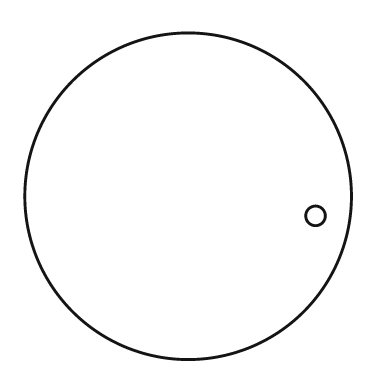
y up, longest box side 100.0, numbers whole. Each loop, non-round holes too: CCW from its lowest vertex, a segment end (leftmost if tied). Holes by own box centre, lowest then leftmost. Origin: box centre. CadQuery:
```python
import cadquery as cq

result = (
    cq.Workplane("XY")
    .moveTo(0.0, 0.0)
    .circle(50.0)
    .moveTo(39.0, -6.0)
    .circle(3.0)
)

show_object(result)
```